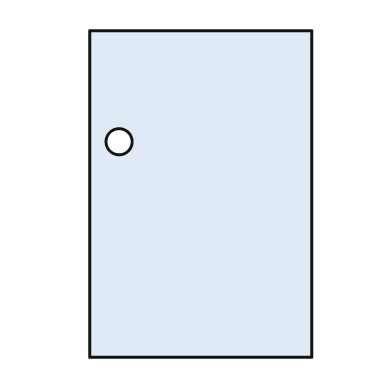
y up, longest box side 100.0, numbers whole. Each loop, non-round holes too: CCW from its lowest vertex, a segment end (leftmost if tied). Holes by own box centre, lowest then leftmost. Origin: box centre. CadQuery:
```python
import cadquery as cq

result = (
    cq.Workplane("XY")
    .moveTo(-34.0, -50.0)
    .lineTo(34.0, -50.0)
    .lineTo(34.0, 50.0)
    .lineTo(-34.0, 50.0)
    .close()
    .moveTo(-25.0, 16.0)
    .circle(4.0)
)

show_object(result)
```